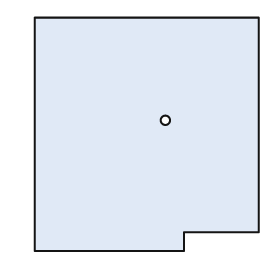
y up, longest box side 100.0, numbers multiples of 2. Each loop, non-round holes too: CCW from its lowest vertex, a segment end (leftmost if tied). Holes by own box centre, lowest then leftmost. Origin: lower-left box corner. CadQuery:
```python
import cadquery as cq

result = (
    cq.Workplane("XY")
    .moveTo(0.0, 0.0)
    .lineTo(64.0, 0.0)
    .lineTo(64.0, 8.0)
    .lineTo(96.0, 8.0)
    .lineTo(96.0, 100.0)
    .lineTo(0.0, 100.0)
    .close()
    .moveTo(56.0, 56.0)
    .circle(2.0)
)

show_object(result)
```